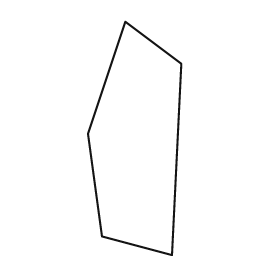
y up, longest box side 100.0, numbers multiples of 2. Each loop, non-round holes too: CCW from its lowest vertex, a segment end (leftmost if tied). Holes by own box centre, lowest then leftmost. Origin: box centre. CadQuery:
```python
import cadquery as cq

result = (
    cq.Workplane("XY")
    .moveTo(16.0, -50.0)
    .lineTo(20.0, 32.0)
    .lineTo(-4.0, 50.0)
    .lineTo(-20.0, 2.0)
    .lineTo(-14.0, -42.0)
    .close()
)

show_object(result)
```